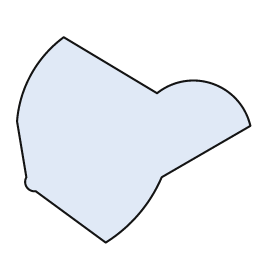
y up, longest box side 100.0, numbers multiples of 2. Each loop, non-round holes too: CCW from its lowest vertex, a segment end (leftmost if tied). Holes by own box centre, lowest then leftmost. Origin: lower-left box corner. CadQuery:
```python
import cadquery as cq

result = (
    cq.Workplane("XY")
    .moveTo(38.0, 0.0)
    .threePointArc((52.0, 12.0), (62.0, 28.0))
    .lineTo(100.0, 50.0)
    .threePointArc((84.0, 68.0), (60.0, 64.0))
    .lineTo(20.0, 88.0)
    .threePointArc((6.0, 72.0), (0.0, 52.0))
    .lineTo(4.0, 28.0)
    .threePointArc((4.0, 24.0), (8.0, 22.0))
    .close()
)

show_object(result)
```